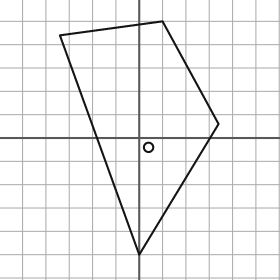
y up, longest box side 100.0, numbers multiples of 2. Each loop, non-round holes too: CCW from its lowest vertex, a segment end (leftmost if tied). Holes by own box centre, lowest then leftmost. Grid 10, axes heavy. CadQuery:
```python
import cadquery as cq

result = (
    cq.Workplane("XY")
    .moveTo(0.0, -50.0)
    .lineTo(34.0, 6.0)
    .lineTo(10.0, 50.0)
    .lineTo(-34.0, 44.0)
    .close()
    .moveTo(4.0, -4.0)
    .circle(2.0)
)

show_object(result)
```